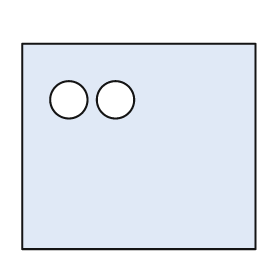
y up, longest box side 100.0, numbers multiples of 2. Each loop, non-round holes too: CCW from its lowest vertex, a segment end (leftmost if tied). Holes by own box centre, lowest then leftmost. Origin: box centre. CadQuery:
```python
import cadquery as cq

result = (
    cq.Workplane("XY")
    .moveTo(-50.0, -44.0)
    .lineTo(50.0, -44.0)
    .lineTo(50.0, 44.0)
    .lineTo(-50.0, 44.0)
    .close()
    .moveTo(-30.0, 20.0)
    .circle(8.0)
    .moveTo(-10.0, 20.0)
    .circle(8.0)
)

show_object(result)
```